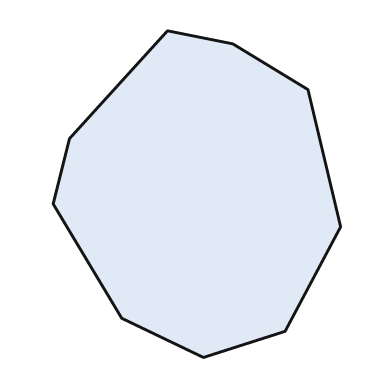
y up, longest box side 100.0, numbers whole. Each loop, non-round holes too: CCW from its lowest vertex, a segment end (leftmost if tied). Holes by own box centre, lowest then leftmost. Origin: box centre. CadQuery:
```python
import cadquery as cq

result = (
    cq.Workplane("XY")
    .moveTo(2.0, -50.0)
    .lineTo(27.0, -42.0)
    .lineTo(44.0, -10.0)
    .lineTo(34.0, 32.0)
    .lineTo(11.0, 46.0)
    .lineTo(-9.0, 50.0)
    .lineTo(-39.0, 17.0)
    .lineTo(-44.0, -3.0)
    .lineTo(-23.0, -38.0)
    .close()
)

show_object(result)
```